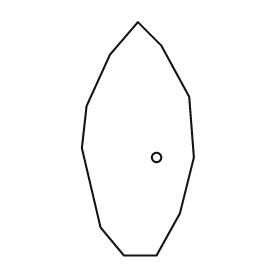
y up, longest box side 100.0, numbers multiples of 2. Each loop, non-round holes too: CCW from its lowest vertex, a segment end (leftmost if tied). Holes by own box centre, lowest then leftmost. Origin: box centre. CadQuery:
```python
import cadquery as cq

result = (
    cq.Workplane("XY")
    .moveTo(-6.0, -50.0)
    .lineTo(8.0, -50.0)
    .lineTo(18.0, -32.0)
    .lineTo(24.0, -8.0)
    .lineTo(22.0, 18.0)
    .lineTo(10.0, 40.0)
    .lineTo(0.0, 50.0)
    .lineTo(-12.0, 36.0)
    .lineTo(-22.0, 14.0)
    .lineTo(-24.0, -4.0)
    .lineTo(-16.0, -38.0)
    .close()
    .moveTo(8.0, -8.0)
    .circle(2.0)
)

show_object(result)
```